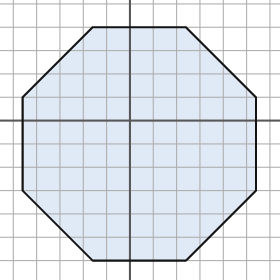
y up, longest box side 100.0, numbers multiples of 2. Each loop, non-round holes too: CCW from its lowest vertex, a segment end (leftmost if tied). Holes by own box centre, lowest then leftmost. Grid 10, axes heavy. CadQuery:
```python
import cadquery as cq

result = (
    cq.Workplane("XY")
    .moveTo(-16.0, -60.0)
    .lineTo(24.0, -60.0)
    .lineTo(54.0, -30.0)
    .lineTo(54.0, 10.0)
    .lineTo(24.0, 40.0)
    .lineTo(-16.0, 40.0)
    .lineTo(-46.0, 10.0)
    .lineTo(-46.0, -30.0)
    .close()
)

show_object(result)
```